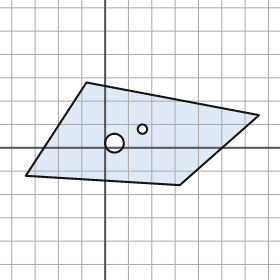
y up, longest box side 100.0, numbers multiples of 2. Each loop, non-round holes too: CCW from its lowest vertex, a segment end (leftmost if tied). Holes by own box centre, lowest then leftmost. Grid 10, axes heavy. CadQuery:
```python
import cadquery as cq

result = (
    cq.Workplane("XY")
    .moveTo(32.0, -16.0)
    .lineTo(66.0, 14.0)
    .lineTo(-8.0, 28.0)
    .lineTo(-34.0, -12.0)
    .close()
    .moveTo(4.0, 2.0)
    .circle(4.0)
    .moveTo(16.0, 8.0)
    .circle(2.0)
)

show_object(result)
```